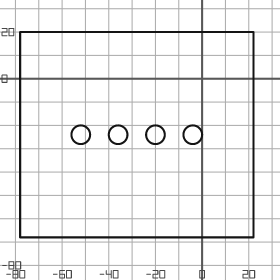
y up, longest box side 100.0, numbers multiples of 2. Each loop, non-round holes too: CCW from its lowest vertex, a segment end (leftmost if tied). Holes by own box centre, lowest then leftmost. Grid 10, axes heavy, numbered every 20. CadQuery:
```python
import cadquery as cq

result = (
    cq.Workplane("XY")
    .moveTo(-78.0, -68.0)
    .lineTo(22.0, -68.0)
    .lineTo(22.0, 20.0)
    .lineTo(-78.0, 20.0)
    .close()
    .moveTo(-52.0, -24.0)
    .circle(4.0)
    .moveTo(-36.0, -24.0)
    .circle(4.0)
    .moveTo(-20.0, -24.0)
    .circle(4.0)
    .moveTo(-4.0, -24.0)
    .circle(4.0)
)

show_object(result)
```